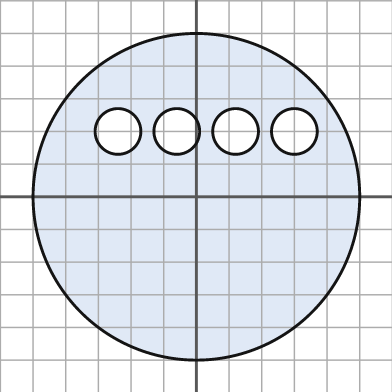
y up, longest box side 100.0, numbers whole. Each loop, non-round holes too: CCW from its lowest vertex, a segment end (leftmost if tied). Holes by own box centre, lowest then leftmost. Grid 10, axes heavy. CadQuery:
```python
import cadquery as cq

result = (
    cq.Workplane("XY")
    .moveTo(0.0, 0.0)
    .circle(50.0)
    .moveTo(-24.0, 20.0)
    .circle(7.0)
    .moveTo(-6.0, 20.0)
    .circle(7.0)
    .moveTo(12.0, 20.0)
    .circle(7.0)
    .moveTo(30.0, 20.0)
    .circle(7.0)
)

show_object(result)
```